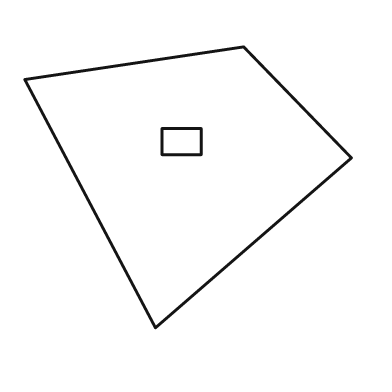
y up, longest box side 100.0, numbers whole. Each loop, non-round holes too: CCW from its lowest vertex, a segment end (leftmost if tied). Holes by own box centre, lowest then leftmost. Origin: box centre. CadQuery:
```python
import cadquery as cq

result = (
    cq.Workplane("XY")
    .moveTo(-10.0, -43.0)
    .lineTo(50.0, 9.0)
    .lineTo(17.0, 43.0)
    .lineTo(-50.0, 33.0)
    .close()
    .moveTo(-8.0, 10.0)
    .lineTo(4.0, 10.0)
    .lineTo(4.0, 18.0)
    .lineTo(-8.0, 18.0)
    .close()
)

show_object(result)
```